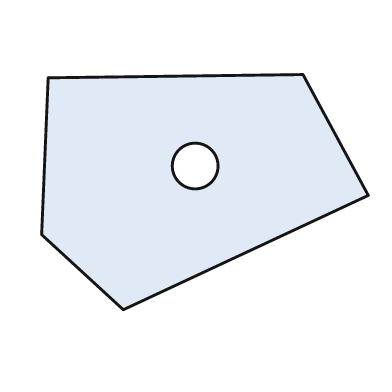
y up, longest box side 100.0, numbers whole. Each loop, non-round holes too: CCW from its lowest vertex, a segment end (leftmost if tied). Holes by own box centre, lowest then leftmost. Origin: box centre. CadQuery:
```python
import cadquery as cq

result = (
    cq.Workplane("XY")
    .moveTo(-25.0, -36.0)
    .lineTo(50.0, -1.0)
    .lineTo(30.0, 36.0)
    .lineTo(-48.0, 35.0)
    .lineTo(-50.0, -13.0)
    .close()
    .moveTo(-3.0, 8.0)
    .circle(7.0)
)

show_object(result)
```